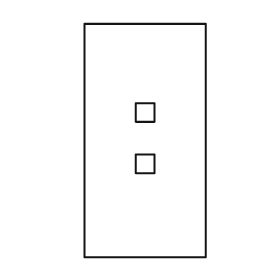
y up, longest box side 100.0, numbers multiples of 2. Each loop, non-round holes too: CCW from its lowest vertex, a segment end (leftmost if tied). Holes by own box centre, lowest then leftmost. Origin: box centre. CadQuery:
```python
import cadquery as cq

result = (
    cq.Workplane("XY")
    .moveTo(-26.0, -50.0)
    .lineTo(26.0, -50.0)
    .lineTo(26.0, 50.0)
    .lineTo(-26.0, 50.0)
    .close()
    .moveTo(-4.0, -14.0)
    .lineTo(4.0, -14.0)
    .lineTo(4.0, -6.0)
    .lineTo(-4.0, -6.0)
    .close()
    .moveTo(-4.0, 8.0)
    .lineTo(4.0, 8.0)
    .lineTo(4.0, 16.0)
    .lineTo(-4.0, 16.0)
    .close()
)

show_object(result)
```